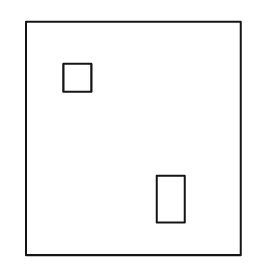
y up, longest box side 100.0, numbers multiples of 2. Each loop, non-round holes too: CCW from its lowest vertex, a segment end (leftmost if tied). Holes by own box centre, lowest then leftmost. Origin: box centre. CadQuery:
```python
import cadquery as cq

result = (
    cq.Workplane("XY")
    .moveTo(-46.0, -50.0)
    .lineTo(46.0, -50.0)
    .lineTo(46.0, 50.0)
    .lineTo(-46.0, 50.0)
    .close()
    .moveTo(10.0, -36.0)
    .lineTo(22.0, -36.0)
    .lineTo(22.0, -16.0)
    .lineTo(10.0, -16.0)
    .close()
    .moveTo(-30.0, 20.0)
    .lineTo(-18.0, 20.0)
    .lineTo(-18.0, 32.0)
    .lineTo(-30.0, 32.0)
    .close()
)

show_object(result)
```